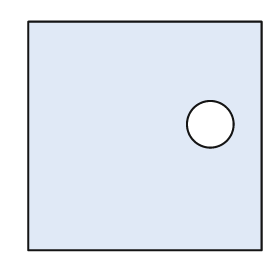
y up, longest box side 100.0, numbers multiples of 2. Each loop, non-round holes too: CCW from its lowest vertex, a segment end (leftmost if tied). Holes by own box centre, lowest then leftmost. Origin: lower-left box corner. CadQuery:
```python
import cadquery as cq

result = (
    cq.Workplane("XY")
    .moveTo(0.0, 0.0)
    .lineTo(100.0, 0.0)
    .lineTo(100.0, 98.0)
    .lineTo(0.0, 98.0)
    .close()
    .moveTo(78.0, 54.0)
    .circle(10.0)
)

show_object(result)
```